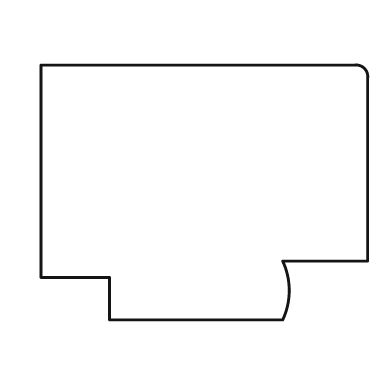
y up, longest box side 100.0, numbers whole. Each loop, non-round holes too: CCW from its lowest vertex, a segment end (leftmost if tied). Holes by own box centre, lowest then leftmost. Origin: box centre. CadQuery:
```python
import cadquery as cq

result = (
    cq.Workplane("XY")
    .moveTo(-29.0, -39.0)
    .lineTo(24.0, -39.0)
    .threePointArc((26.0, -30.0), (24.0, -21.0))
    .lineTo(50.0, -21.0)
    .lineTo(50.0, 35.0)
    .threePointArc((49.0, 38.0), (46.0, 39.0))
    .lineTo(-50.0, 39.0)
    .lineTo(-50.0, -26.0)
    .lineTo(-29.0, -26.0)
    .close()
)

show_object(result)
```